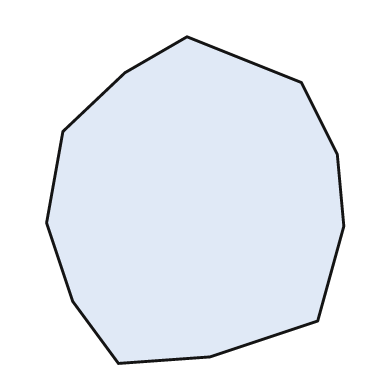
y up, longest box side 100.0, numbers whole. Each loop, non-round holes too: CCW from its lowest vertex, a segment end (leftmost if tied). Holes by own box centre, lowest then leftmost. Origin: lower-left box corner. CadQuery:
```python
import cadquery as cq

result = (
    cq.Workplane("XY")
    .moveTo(22.0, 0.0)
    .lineTo(50.0, 2.0)
    .lineTo(83.0, 13.0)
    .lineTo(91.0, 42.0)
    .lineTo(89.0, 64.0)
    .lineTo(78.0, 86.0)
    .lineTo(43.0, 100.0)
    .lineTo(24.0, 89.0)
    .lineTo(5.0, 71.0)
    .lineTo(0.0, 43.0)
    .lineTo(8.0, 19.0)
    .close()
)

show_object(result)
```